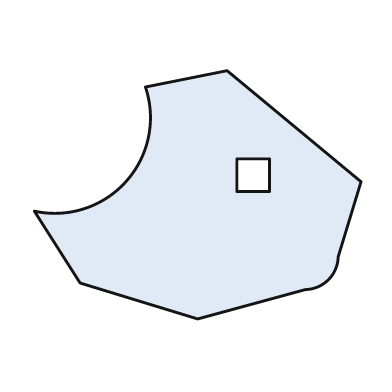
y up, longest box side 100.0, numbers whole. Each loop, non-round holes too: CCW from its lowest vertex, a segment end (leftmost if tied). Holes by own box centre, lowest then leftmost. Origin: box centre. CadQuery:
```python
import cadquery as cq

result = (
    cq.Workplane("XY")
    .moveTo(0.0, -38.0)
    .lineTo(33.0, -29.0)
    .threePointArc((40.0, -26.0), (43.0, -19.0))
    .lineTo(50.0, 4.0)
    .lineTo(9.0, 38.0)
    .lineTo(-16.0, 33.0)
    .threePointArc((-22.0, 4.0), (-50.0, -5.0))
    .lineTo(-36.0, -27.0)
    .close()
    .moveTo(12.0, 1.0)
    .lineTo(22.0, 1.0)
    .lineTo(22.0, 11.0)
    .lineTo(12.0, 11.0)
    .close()
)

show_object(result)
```